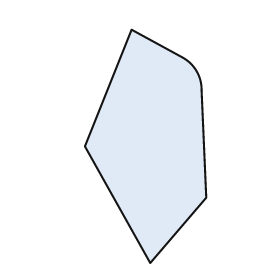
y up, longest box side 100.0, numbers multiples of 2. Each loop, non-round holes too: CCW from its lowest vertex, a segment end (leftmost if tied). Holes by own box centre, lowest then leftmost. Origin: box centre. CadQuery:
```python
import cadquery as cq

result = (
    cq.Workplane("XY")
    .moveTo(2.0, -50.0)
    .lineTo(26.0, -22.0)
    .lineTo(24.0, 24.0)
    .threePointArc((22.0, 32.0), (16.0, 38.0))
    .lineTo(-6.0, 50.0)
    .lineTo(-26.0, 0.0)
    .close()
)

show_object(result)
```